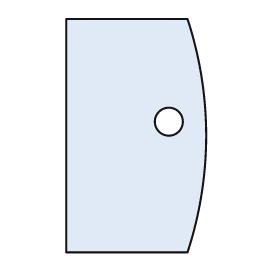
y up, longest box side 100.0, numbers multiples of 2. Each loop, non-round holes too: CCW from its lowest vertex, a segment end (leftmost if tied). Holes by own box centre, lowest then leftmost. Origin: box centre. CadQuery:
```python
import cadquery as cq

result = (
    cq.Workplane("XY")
    .moveTo(-30.0, -50.0)
    .lineTo(22.0, -50.0)
    .threePointArc((30.0, 0.0), (22.0, 50.0))
    .lineTo(-30.0, 50.0)
    .close()
    .moveTo(14.0, 6.0)
    .circle(6.0)
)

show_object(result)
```